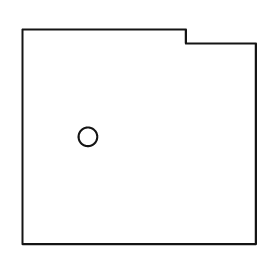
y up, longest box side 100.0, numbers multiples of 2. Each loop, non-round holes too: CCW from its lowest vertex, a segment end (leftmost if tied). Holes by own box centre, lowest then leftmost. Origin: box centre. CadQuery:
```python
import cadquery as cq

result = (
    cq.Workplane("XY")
    .moveTo(-50.0, -46.0)
    .lineTo(50.0, -46.0)
    .lineTo(50.0, 40.0)
    .lineTo(20.0, 40.0)
    .lineTo(20.0, 46.0)
    .lineTo(-50.0, 46.0)
    .close()
    .moveTo(-22.0, 0.0)
    .circle(4.0)
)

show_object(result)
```